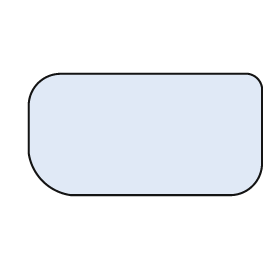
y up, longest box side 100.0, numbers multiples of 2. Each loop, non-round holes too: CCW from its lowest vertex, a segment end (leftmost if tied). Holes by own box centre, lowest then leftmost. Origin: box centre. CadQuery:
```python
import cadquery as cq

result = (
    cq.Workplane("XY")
    .moveTo(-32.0, -26.0)
    .lineTo(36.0, -26.0)
    .threePointArc((46.0, -22.0), (50.0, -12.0))
    .lineTo(50.0, 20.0)
    .threePointArc((48.0, 24.0), (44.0, 26.0))
    .lineTo(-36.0, 26.0)
    .threePointArc((-46.0, 22.0), (-50.0, 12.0))
    .lineTo(-50.0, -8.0)
    .threePointArc((-44.0, -20.0), (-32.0, -26.0))
    .close()
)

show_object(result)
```